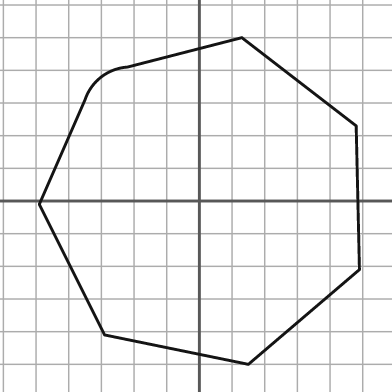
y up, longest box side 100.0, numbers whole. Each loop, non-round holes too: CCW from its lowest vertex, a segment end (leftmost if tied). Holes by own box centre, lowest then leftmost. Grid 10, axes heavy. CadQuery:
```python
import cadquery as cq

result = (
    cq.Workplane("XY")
    .moveTo(15.0, -50.0)
    .lineTo(49.0, -21.0)
    .lineTo(48.0, 23.0)
    .lineTo(13.0, 50.0)
    .lineTo(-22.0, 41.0)
    .threePointArc((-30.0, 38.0), (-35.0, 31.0))
    .lineTo(-49.0, -1.0)
    .lineTo(-29.0, -41.0)
    .close()
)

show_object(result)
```